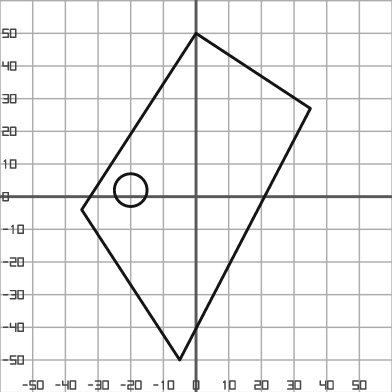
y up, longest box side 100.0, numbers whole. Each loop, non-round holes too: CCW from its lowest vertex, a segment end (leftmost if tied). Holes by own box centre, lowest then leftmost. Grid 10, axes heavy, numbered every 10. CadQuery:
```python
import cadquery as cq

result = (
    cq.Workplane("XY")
    .moveTo(-5.0, -50.0)
    .lineTo(35.0, 27.0)
    .lineTo(0.0, 50.0)
    .lineTo(-35.0, -4.0)
    .close()
    .moveTo(-20.0, 2.0)
    .circle(5.0)
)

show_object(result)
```